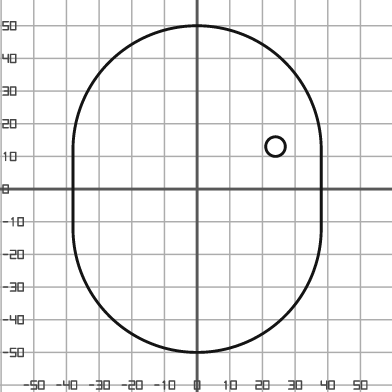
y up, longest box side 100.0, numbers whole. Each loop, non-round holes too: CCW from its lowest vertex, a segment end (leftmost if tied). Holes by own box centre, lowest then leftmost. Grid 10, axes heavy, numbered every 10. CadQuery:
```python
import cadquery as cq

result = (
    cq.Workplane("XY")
    .moveTo(-38.0, -12.0)
    .threePointArc((0.0, -50.0), (38.0, -12.0))
    .lineTo(38.0, 12.0)
    .threePointArc((0.0, 50.0), (-38.0, 12.0))
    .close()
    .moveTo(24.0, 13.0)
    .circle(3.0)
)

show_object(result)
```